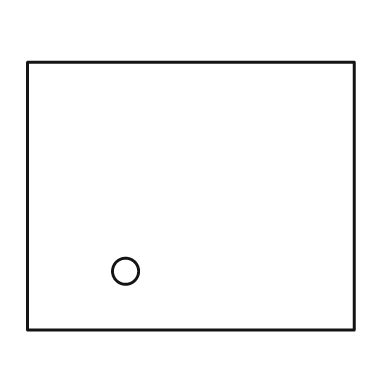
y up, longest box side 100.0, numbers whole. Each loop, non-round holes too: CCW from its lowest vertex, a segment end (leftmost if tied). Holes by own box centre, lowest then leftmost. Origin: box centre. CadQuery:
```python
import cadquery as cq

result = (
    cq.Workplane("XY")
    .moveTo(-50.0, -41.0)
    .lineTo(50.0, -41.0)
    .lineTo(50.0, 41.0)
    .lineTo(-50.0, 41.0)
    .close()
    .moveTo(-20.0, -23.0)
    .circle(4.0)
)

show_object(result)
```